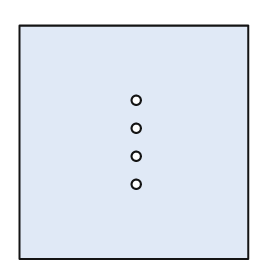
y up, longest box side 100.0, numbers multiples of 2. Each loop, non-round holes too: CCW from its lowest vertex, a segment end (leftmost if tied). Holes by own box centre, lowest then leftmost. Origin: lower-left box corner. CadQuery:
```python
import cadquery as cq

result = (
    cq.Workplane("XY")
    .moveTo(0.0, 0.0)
    .lineTo(98.0, 0.0)
    .lineTo(98.0, 100.0)
    .lineTo(0.0, 100.0)
    .close()
    .moveTo(50.0, 32.0)
    .circle(2.0)
    .moveTo(50.0, 44.0)
    .circle(2.0)
    .moveTo(50.0, 56.0)
    .circle(2.0)
    .moveTo(50.0, 68.0)
    .circle(2.0)
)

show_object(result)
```